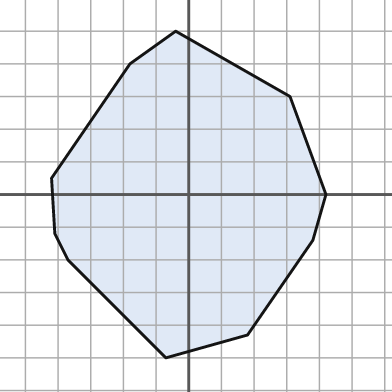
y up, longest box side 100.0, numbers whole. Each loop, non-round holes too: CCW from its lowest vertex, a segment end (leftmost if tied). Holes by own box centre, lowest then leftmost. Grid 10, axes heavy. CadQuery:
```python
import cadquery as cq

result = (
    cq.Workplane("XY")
    .moveTo(-7.0, -50.0)
    .lineTo(18.0, -43.0)
    .lineTo(38.0, -14.0)
    .lineTo(42.0, 0.0)
    .lineTo(31.0, 30.0)
    .lineTo(-4.0, 50.0)
    .lineTo(-18.0, 40.0)
    .lineTo(-42.0, 5.0)
    .lineTo(-41.0, -12.0)
    .lineTo(-37.0, -20.0)
    .close()
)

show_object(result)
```